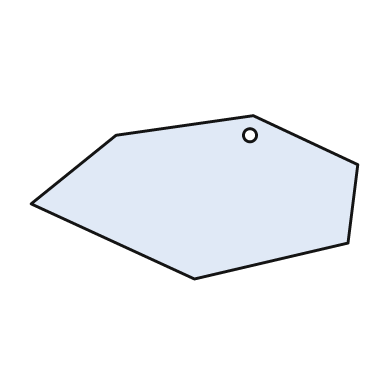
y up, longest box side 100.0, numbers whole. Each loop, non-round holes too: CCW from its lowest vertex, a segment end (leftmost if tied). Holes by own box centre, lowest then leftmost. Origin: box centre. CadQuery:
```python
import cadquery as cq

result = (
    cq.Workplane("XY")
    .moveTo(0.0, -25.0)
    .lineTo(47.0, -14.0)
    .lineTo(50.0, 10.0)
    .lineTo(18.0, 25.0)
    .lineTo(-24.0, 19.0)
    .lineTo(-50.0, -2.0)
    .close()
    .moveTo(17.0, 19.0)
    .circle(2.0)
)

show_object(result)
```